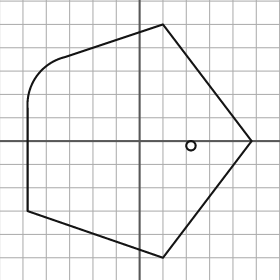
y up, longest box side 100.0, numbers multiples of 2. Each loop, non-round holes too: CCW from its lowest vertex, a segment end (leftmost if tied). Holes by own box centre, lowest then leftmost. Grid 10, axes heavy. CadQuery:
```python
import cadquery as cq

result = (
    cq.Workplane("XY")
    .moveTo(10.0, -50.0)
    .lineTo(48.0, 0.0)
    .lineTo(10.0, 50.0)
    .lineTo(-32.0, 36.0)
    .threePointArc((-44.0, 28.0), (-48.0, 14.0))
    .lineTo(-48.0, -30.0)
    .close()
    .moveTo(22.0, -2.0)
    .circle(2.0)
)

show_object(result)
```